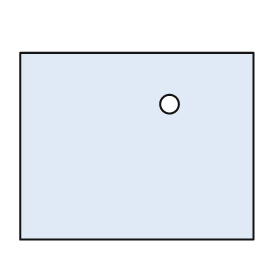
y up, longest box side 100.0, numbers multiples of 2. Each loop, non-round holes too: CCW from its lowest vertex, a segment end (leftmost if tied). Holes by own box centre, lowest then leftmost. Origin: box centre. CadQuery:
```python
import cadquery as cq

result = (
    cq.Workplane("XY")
    .moveTo(-50.0, -40.0)
    .lineTo(50.0, -40.0)
    .lineTo(50.0, 40.0)
    .lineTo(-50.0, 40.0)
    .close()
    .moveTo(14.0, 18.0)
    .circle(4.0)
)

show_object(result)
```